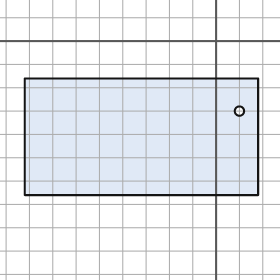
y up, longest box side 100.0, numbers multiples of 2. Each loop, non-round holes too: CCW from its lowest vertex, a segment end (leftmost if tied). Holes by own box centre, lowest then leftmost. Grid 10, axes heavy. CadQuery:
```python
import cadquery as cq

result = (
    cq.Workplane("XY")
    .moveTo(-82.0, -66.0)
    .lineTo(18.0, -66.0)
    .lineTo(18.0, -16.0)
    .lineTo(-82.0, -16.0)
    .close()
    .moveTo(10.0, -30.0)
    .circle(2.0)
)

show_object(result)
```